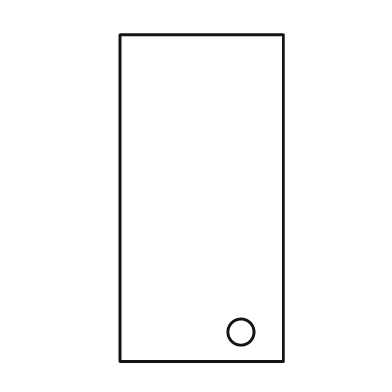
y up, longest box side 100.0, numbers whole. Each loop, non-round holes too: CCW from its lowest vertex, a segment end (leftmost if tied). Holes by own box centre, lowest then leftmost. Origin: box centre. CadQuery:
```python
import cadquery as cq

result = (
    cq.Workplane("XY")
    .moveTo(-25.0, -50.0)
    .lineTo(25.0, -50.0)
    .lineTo(25.0, 50.0)
    .lineTo(-25.0, 50.0)
    .close()
    .moveTo(12.0, -41.0)
    .circle(4.0)
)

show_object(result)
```